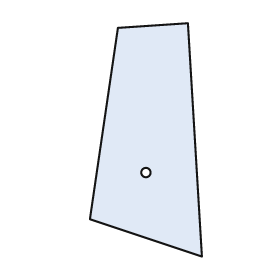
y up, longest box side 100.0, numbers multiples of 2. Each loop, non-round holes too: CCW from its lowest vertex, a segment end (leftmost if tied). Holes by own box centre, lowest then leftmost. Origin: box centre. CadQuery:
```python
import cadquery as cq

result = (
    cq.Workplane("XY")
    .moveTo(24.0, -50.0)
    .lineTo(18.0, 50.0)
    .lineTo(-12.0, 48.0)
    .lineTo(-24.0, -34.0)
    .close()
    .moveTo(0.0, -14.0)
    .circle(2.0)
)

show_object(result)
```